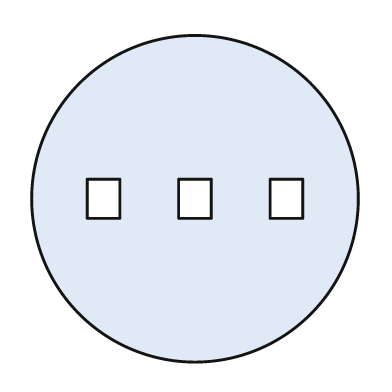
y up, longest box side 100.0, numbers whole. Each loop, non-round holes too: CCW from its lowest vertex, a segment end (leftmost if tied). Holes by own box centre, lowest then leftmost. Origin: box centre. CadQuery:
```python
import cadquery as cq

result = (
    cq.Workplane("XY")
    .moveTo(0.0, 0.0)
    .circle(50.0)
    .moveTo(-33.0, -6.0)
    .lineTo(-23.0, -6.0)
    .lineTo(-23.0, 6.0)
    .lineTo(-33.0, 6.0)
    .close()
    .moveTo(-5.0, -6.0)
    .lineTo(5.0, -6.0)
    .lineTo(5.0, 6.0)
    .lineTo(-5.0, 6.0)
    .close()
    .moveTo(23.0, -6.0)
    .lineTo(33.0, -6.0)
    .lineTo(33.0, 6.0)
    .lineTo(23.0, 6.0)
    .close()
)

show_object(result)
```